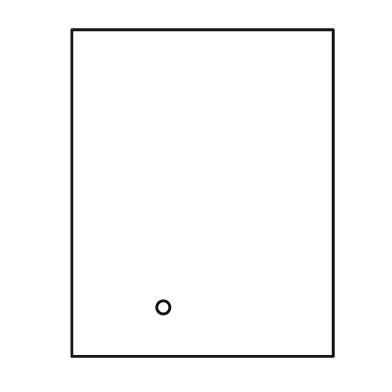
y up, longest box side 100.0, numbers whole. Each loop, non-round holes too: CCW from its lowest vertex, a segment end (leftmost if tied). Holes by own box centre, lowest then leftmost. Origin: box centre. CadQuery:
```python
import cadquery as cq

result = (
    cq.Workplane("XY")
    .moveTo(-40.0, -50.0)
    .lineTo(40.0, -50.0)
    .lineTo(40.0, 50.0)
    .lineTo(-40.0, 50.0)
    .close()
    .moveTo(-12.0, -35.0)
    .circle(2.0)
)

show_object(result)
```